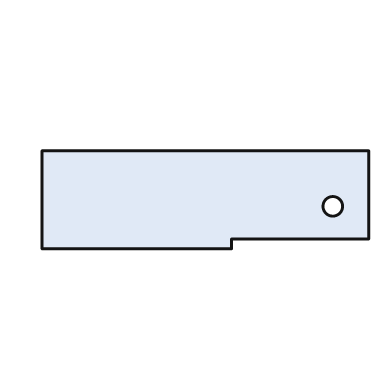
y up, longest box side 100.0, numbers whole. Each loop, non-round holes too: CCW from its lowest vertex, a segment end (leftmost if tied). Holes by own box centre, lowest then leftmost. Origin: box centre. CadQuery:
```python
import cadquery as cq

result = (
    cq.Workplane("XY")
    .moveTo(-50.0, -15.0)
    .lineTo(8.0, -15.0)
    .lineTo(8.0, -12.0)
    .lineTo(50.0, -12.0)
    .lineTo(50.0, 15.0)
    .lineTo(-50.0, 15.0)
    .close()
    .moveTo(39.0, -2.0)
    .circle(3.0)
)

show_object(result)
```